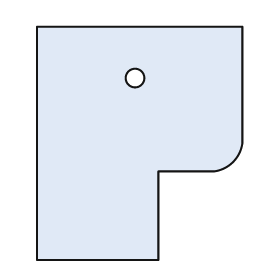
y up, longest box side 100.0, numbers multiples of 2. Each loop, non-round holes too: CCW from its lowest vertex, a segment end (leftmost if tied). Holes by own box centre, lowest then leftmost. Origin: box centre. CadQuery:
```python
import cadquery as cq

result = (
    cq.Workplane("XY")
    .moveTo(-44.0, -50.0)
    .lineTo(8.0, -50.0)
    .lineTo(8.0, -12.0)
    .lineTo(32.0, -12.0)
    .threePointArc((40.0, -8.0), (44.0, 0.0))
    .lineTo(44.0, 50.0)
    .lineTo(-44.0, 50.0)
    .close()
    .moveTo(-2.0, 28.0)
    .circle(4.0)
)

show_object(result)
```